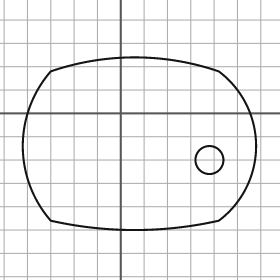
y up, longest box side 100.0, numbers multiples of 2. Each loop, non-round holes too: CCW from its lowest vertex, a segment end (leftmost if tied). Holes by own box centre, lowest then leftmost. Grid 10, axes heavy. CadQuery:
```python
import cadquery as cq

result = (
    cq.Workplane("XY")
    .moveTo(-30.0, -46.0)
    .threePointArc((6.0, -50.0), (42.0, -46.0))
    .threePointArc((58.0, -14.0), (42.0, 18.0))
    .threePointArc((6.0, 24.0), (-30.0, 18.0))
    .threePointArc((-42.0, -14.0), (-30.0, -46.0))
    .close()
    .moveTo(38.0, -20.0)
    .circle(6.0)
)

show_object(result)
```